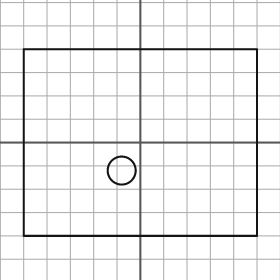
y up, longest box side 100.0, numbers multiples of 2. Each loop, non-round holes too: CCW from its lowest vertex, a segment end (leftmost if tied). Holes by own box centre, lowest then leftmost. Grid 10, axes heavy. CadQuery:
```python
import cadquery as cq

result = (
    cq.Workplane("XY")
    .moveTo(-50.0, -40.0)
    .lineTo(50.0, -40.0)
    .lineTo(50.0, 40.0)
    .lineTo(-50.0, 40.0)
    .close()
    .moveTo(-8.0, -12.0)
    .circle(6.0)
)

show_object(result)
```